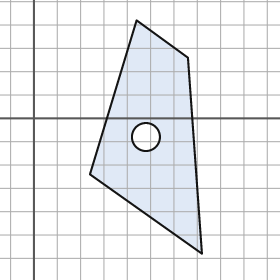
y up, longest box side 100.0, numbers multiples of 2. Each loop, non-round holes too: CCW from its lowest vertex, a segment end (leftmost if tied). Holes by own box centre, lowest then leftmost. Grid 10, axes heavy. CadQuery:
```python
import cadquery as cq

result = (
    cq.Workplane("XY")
    .moveTo(72.0, -58.0)
    .lineTo(66.0, 26.0)
    .lineTo(44.0, 42.0)
    .lineTo(24.0, -24.0)
    .close()
    .moveTo(48.0, -8.0)
    .circle(6.0)
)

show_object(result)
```